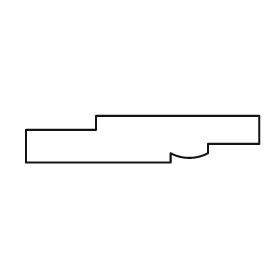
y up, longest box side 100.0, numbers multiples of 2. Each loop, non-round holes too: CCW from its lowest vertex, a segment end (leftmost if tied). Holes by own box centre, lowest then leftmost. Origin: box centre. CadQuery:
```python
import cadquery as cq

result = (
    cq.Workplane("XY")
    .moveTo(-50.0, -10.0)
    .lineTo(12.0, -10.0)
    .lineTo(12.0, -6.0)
    .threePointArc((20.0, -8.0), (28.0, -6.0))
    .lineTo(28.0, -2.0)
    .lineTo(50.0, -2.0)
    .lineTo(50.0, 10.0)
    .lineTo(-20.0, 10.0)
    .lineTo(-20.0, 4.0)
    .lineTo(-50.0, 4.0)
    .close()
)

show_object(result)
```